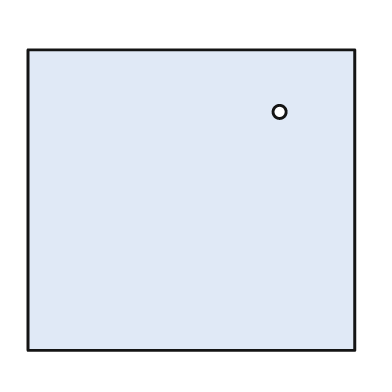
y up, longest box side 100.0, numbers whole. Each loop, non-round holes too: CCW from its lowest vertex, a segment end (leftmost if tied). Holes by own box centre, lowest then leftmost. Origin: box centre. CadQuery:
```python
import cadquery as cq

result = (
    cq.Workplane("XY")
    .moveTo(-50.0, -46.0)
    .lineTo(50.0, -46.0)
    .lineTo(50.0, 46.0)
    .lineTo(-50.0, 46.0)
    .close()
    .moveTo(27.0, 27.0)
    .circle(2.0)
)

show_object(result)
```